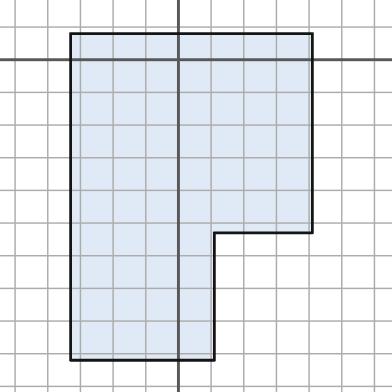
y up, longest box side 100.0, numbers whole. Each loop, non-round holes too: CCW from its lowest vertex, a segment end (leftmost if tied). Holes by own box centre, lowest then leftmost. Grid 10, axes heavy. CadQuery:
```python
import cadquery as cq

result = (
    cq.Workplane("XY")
    .moveTo(-33.0, -92.0)
    .lineTo(11.0, -92.0)
    .lineTo(11.0, -53.0)
    .lineTo(41.0, -53.0)
    .lineTo(41.0, 8.0)
    .lineTo(-33.0, 8.0)
    .close()
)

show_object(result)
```